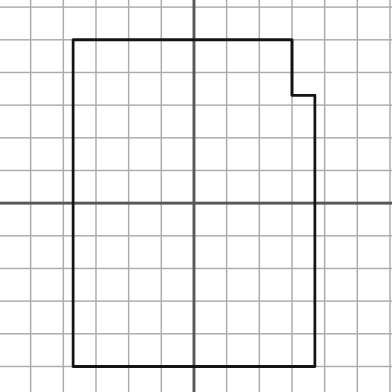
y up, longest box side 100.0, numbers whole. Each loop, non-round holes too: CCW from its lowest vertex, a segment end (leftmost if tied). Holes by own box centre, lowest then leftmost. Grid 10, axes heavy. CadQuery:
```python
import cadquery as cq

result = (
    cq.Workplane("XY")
    .moveTo(-37.0, -50.0)
    .lineTo(37.0, -50.0)
    .lineTo(37.0, 33.0)
    .lineTo(30.0, 33.0)
    .lineTo(30.0, 50.0)
    .lineTo(-37.0, 50.0)
    .close()
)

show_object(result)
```